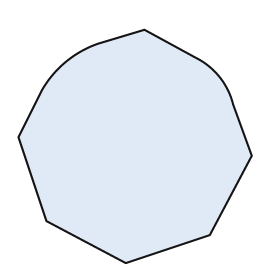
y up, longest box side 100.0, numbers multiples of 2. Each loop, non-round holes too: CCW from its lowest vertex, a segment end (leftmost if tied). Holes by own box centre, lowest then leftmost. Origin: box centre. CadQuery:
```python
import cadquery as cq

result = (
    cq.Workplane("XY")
    .moveTo(-4.0, -50.0)
    .lineTo(32.0, -38.0)
    .lineTo(50.0, -4.0)
    .lineTo(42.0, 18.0)
    .threePointArc((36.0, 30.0), (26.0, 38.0))
    .lineTo(4.0, 50.0)
    .lineTo(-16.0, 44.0)
    .threePointArc((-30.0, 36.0), (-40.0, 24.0))
    .lineTo(-50.0, 4.0)
    .lineTo(-38.0, -32.0)
    .close()
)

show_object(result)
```